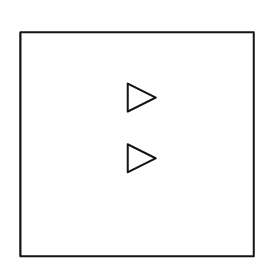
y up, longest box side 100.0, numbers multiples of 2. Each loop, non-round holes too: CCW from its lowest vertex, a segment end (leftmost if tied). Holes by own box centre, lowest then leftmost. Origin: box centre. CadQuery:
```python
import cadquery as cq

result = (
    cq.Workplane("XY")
    .moveTo(-50.0, -48.0)
    .lineTo(50.0, -48.0)
    .lineTo(50.0, 48.0)
    .lineTo(-50.0, 48.0)
    .close()
    .moveTo(-4.0, -12.0)
    .lineTo(8.0, -6.0)
    .lineTo(-4.0, 0.0)
    .close()
    .moveTo(-4.0, 14.0)
    .lineTo(8.0, 20.0)
    .lineTo(-4.0, 26.0)
    .close()
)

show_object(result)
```